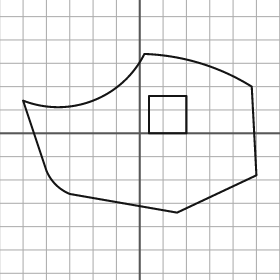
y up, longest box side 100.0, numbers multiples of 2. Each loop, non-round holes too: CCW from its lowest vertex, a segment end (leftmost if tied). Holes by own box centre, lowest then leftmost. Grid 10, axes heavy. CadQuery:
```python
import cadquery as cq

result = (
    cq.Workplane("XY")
    .moveTo(16.0, -34.0)
    .lineTo(50.0, -18.0)
    .lineTo(48.0, 20.0)
    .threePointArc((26.0, 30.0), (2.0, 34.0))
    .threePointArc((-20.0, 14.0), (-50.0, 14.0))
    .lineTo(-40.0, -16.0)
    .threePointArc((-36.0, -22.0), (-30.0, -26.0))
    .close()
    .moveTo(4.0, 0.0)
    .lineTo(20.0, 0.0)
    .lineTo(20.0, 16.0)
    .lineTo(4.0, 16.0)
    .close()
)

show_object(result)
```